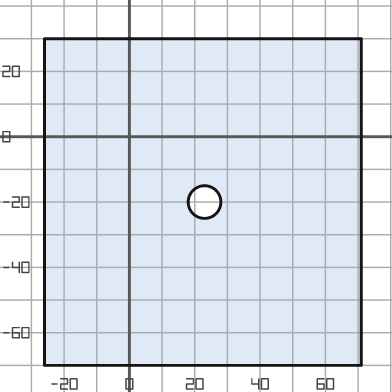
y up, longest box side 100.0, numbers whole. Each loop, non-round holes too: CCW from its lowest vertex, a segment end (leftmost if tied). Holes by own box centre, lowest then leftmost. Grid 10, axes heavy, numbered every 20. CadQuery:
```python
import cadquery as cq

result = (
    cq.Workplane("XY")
    .moveTo(-26.0, -70.0)
    .lineTo(71.0, -70.0)
    .lineTo(71.0, 30.0)
    .lineTo(-26.0, 30.0)
    .close()
    .moveTo(23.0, -20.0)
    .circle(5.0)
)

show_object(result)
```